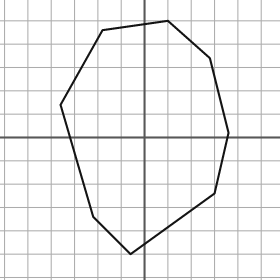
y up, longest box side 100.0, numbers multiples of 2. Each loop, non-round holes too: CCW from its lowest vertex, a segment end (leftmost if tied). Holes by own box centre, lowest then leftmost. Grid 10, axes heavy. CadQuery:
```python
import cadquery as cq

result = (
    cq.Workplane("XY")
    .moveTo(-6.0, -50.0)
    .lineTo(30.0, -24.0)
    .lineTo(36.0, 2.0)
    .lineTo(28.0, 34.0)
    .lineTo(10.0, 50.0)
    .lineTo(-18.0, 46.0)
    .lineTo(-36.0, 14.0)
    .lineTo(-22.0, -34.0)
    .close()
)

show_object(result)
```